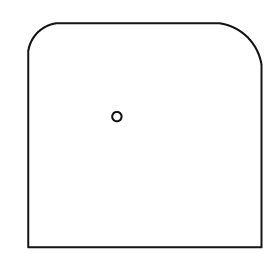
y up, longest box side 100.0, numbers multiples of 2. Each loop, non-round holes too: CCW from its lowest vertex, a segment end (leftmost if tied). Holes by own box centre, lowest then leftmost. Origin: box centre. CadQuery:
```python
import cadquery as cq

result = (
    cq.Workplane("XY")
    .moveTo(-50.0, -48.0)
    .lineTo(50.0, -48.0)
    .lineTo(50.0, 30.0)
    .threePointArc((44.0, 42.0), (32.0, 48.0))
    .lineTo(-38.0, 48.0)
    .threePointArc((-46.0, 44.0), (-50.0, 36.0))
    .close()
    .moveTo(-12.0, 8.0)
    .circle(2.0)
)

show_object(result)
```